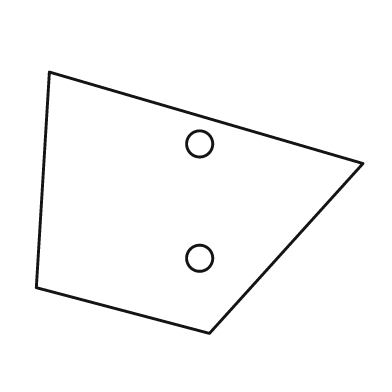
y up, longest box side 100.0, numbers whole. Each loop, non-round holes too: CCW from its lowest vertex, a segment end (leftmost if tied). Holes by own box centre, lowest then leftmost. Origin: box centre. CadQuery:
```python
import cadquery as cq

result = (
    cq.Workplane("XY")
    .moveTo(3.0, -40.0)
    .lineTo(50.0, 12.0)
    .lineTo(-46.0, 40.0)
    .lineTo(-50.0, -26.0)
    .close()
    .moveTo(0.0, -17.0)
    .circle(4.0)
    .moveTo(0.0, 18.0)
    .circle(4.0)
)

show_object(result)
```